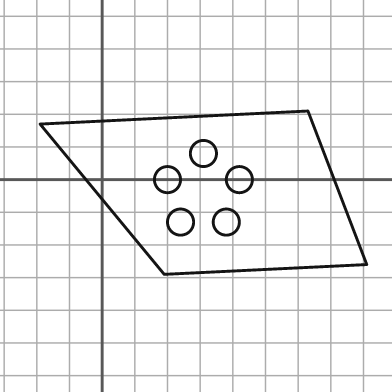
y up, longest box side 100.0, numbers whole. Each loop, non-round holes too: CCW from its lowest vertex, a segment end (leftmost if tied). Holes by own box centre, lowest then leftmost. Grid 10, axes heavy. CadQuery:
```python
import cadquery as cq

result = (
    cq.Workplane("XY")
    .moveTo(19.0, -29.0)
    .lineTo(81.0, -26.0)
    .lineTo(63.0, 21.0)
    .lineTo(-19.0, 17.0)
    .close()
    .moveTo(24.0, -13.0)
    .circle(4.0)
    .moveTo(38.0, -13.0)
    .circle(4.0)
    .moveTo(20.0, 0.0)
    .circle(4.0)
    .moveTo(42.0, 0.0)
    .circle(4.0)
    .moveTo(31.0, 8.0)
    .circle(4.0)
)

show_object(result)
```